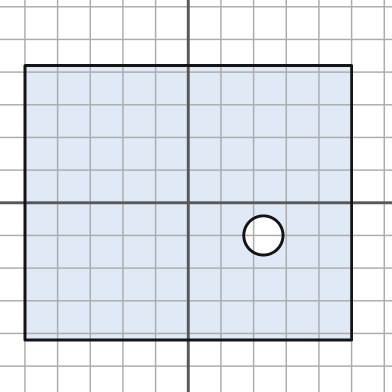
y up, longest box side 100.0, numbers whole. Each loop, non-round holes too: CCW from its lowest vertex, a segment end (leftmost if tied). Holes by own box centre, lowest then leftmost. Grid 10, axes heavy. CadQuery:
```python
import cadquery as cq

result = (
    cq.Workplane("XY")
    .moveTo(-50.0, -42.0)
    .lineTo(50.0, -42.0)
    .lineTo(50.0, 42.0)
    .lineTo(-50.0, 42.0)
    .close()
    .moveTo(23.0, -10.0)
    .circle(6.0)
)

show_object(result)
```